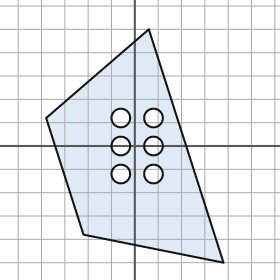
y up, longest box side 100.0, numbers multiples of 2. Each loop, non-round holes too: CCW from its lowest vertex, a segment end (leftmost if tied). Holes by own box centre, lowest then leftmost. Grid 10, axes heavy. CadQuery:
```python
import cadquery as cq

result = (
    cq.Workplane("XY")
    .moveTo(38.0, -50.0)
    .lineTo(6.0, 50.0)
    .lineTo(-38.0, 12.0)
    .lineTo(-22.0, -38.0)
    .close()
    .moveTo(-6.0, -12.0)
    .circle(4.0)
    .moveTo(8.0, -12.0)
    .circle(4.0)
    .moveTo(-6.0, 0.0)
    .circle(4.0)
    .moveTo(8.0, 0.0)
    .circle(4.0)
    .moveTo(-6.0, 12.0)
    .circle(4.0)
    .moveTo(8.0, 12.0)
    .circle(4.0)
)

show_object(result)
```